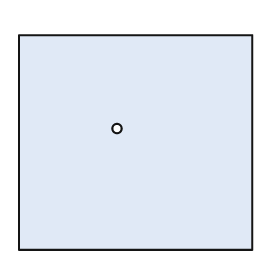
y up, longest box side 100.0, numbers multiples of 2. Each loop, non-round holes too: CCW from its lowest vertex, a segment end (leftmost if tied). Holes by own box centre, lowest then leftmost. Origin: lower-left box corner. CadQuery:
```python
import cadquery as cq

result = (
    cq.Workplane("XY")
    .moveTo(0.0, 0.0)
    .lineTo(100.0, 0.0)
    .lineTo(100.0, 92.0)
    .lineTo(0.0, 92.0)
    .close()
    .moveTo(42.0, 52.0)
    .circle(2.0)
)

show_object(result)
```